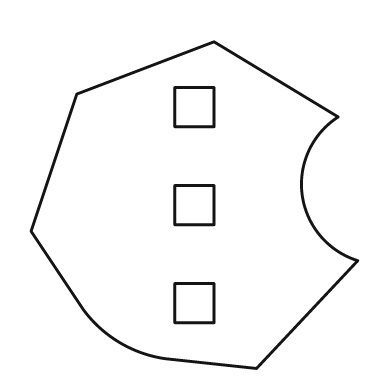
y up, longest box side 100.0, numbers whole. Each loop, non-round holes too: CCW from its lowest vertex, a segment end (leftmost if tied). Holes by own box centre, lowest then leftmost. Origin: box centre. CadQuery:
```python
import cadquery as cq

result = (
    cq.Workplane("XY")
    .moveTo(19.0, -50.0)
    .lineTo(50.0, -17.0)
    .threePointArc((33.0, 3.0), (44.0, 27.0))
    .lineTo(6.0, 50.0)
    .lineTo(-36.0, 34.0)
    .lineTo(-50.0, -8.0)
    .lineTo(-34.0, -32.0)
    .threePointArc((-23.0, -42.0), (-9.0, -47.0))
    .close()
    .moveTo(-6.0, -36.0)
    .lineTo(6.0, -36.0)
    .lineTo(6.0, -24.0)
    .lineTo(-6.0, -24.0)
    .close()
    .moveTo(-6.0, -6.0)
    .lineTo(6.0, -6.0)
    .lineTo(6.0, 6.0)
    .lineTo(-6.0, 6.0)
    .close()
    .moveTo(-6.0, 24.0)
    .lineTo(6.0, 24.0)
    .lineTo(6.0, 36.0)
    .lineTo(-6.0, 36.0)
    .close()
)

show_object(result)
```